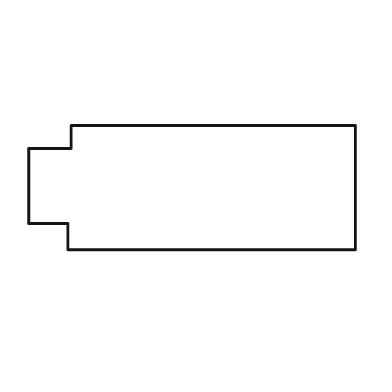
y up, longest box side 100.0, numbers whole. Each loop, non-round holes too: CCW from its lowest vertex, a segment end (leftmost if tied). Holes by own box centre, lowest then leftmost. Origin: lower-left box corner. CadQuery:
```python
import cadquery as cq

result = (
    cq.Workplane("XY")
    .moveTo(12.0, 0.0)
    .lineTo(100.0, 0.0)
    .lineTo(100.0, 38.0)
    .lineTo(13.0, 38.0)
    .lineTo(13.0, 31.0)
    .lineTo(0.0, 31.0)
    .lineTo(0.0, 8.0)
    .lineTo(12.0, 8.0)
    .close()
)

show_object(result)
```